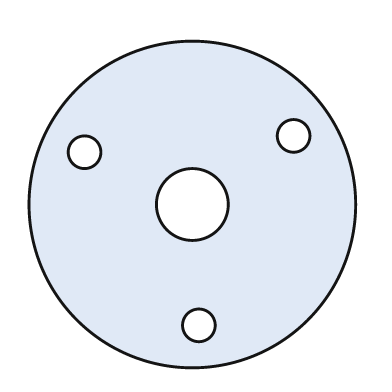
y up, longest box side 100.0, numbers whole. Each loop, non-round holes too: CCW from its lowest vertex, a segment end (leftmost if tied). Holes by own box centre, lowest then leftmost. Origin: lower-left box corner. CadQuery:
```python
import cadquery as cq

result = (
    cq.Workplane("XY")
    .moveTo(50.0, 50.0)
    .circle(50.0)
    .moveTo(52.0, 13.0)
    .circle(5.0)
    .moveTo(50.0, 50.0)
    .circle(11.0)
    .moveTo(17.0, 66.0)
    .circle(5.0)
    .moveTo(81.0, 71.0)
    .circle(5.0)
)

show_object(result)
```